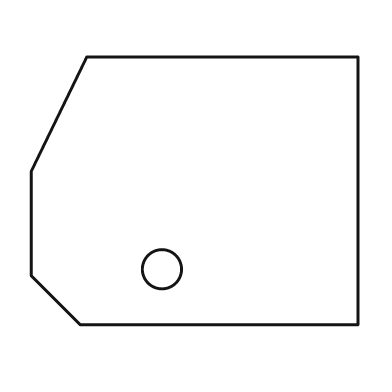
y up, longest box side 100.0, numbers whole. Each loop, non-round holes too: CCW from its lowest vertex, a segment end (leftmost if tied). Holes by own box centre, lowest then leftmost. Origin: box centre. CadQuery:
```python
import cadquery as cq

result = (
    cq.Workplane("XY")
    .moveTo(-35.0, -41.0)
    .lineTo(50.0, -41.0)
    .lineTo(50.0, 41.0)
    .lineTo(-33.0, 41.0)
    .lineTo(-50.0, 6.0)
    .lineTo(-50.0, -26.0)
    .close()
    .moveTo(-10.0, -24.0)
    .circle(6.0)
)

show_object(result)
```